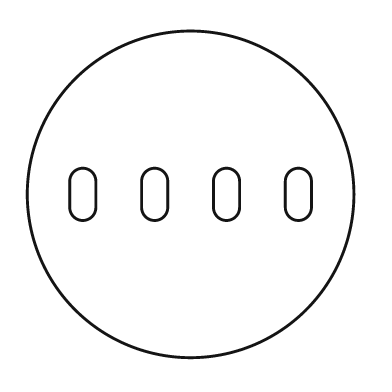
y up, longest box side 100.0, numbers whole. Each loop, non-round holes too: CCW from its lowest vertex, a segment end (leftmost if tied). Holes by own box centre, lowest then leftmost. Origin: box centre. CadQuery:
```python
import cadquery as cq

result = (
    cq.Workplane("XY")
    .moveTo(0.0, 0.0)
    .circle(50.0)
    .moveTo(-37.0, -4.0)
    .threePointArc((-33.0, -8.0), (-29.0, -4.0))
    .lineTo(-29.0, 4.0)
    .threePointArc((-33.0, 8.0), (-37.0, 4.0))
    .close()
    .moveTo(-15.0, -4.0)
    .threePointArc((-11.0, -8.0), (-7.0, -4.0))
    .lineTo(-7.0, 4.0)
    .threePointArc((-11.0, 8.0), (-15.0, 4.0))
    .close()
    .moveTo(7.0, -4.0)
    .threePointArc((11.0, -8.0), (15.0, -4.0))
    .lineTo(15.0, 4.0)
    .threePointArc((11.0, 8.0), (7.0, 4.0))
    .close()
    .moveTo(29.0, -4.0)
    .threePointArc((33.0, -8.0), (37.0, -4.0))
    .lineTo(37.0, 4.0)
    .threePointArc((33.0, 8.0), (29.0, 4.0))
    .close()
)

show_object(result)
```